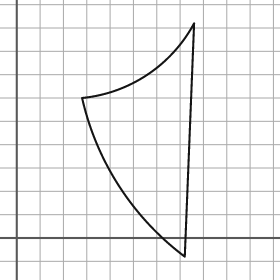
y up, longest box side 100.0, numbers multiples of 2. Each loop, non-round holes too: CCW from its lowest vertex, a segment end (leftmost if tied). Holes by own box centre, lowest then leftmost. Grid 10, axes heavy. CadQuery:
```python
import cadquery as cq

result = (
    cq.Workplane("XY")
    .moveTo(72.0, -8.0)
    .lineTo(76.0, 92.0)
    .threePointArc((56.0, 70.0), (28.0, 60.0))
    .threePointArc((44.0, 22.0), (72.0, -8.0))
    .close()
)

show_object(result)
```